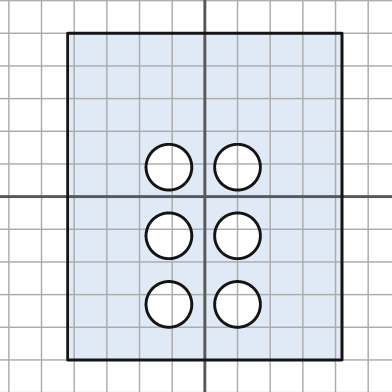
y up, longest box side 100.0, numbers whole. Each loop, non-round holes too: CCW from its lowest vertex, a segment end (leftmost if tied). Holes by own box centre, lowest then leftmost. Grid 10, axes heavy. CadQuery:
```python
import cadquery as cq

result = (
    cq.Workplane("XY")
    .moveTo(-42.0, -50.0)
    .lineTo(42.0, -50.0)
    .lineTo(42.0, 50.0)
    .lineTo(-42.0, 50.0)
    .close()
    .moveTo(-11.0, -33.0)
    .circle(7.0)
    .moveTo(10.0, -33.0)
    .circle(7.0)
    .moveTo(-11.0, -12.0)
    .circle(7.0)
    .moveTo(10.0, -12.0)
    .circle(7.0)
    .moveTo(-11.0, 9.0)
    .circle(7.0)
    .moveTo(10.0, 9.0)
    .circle(7.0)
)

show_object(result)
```